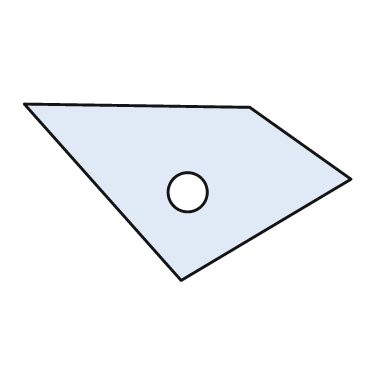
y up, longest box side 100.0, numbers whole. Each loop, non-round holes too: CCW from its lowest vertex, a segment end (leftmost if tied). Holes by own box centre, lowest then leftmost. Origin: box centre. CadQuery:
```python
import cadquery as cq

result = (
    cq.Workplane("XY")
    .moveTo(-2.0, -27.0)
    .lineTo(50.0, 4.0)
    .lineTo(19.0, 26.0)
    .lineTo(-50.0, 27.0)
    .close()
    .moveTo(0.0, 0.0)
    .circle(6.0)
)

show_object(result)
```